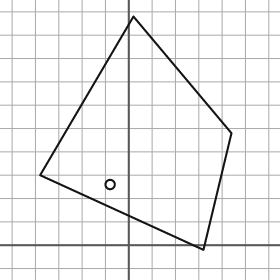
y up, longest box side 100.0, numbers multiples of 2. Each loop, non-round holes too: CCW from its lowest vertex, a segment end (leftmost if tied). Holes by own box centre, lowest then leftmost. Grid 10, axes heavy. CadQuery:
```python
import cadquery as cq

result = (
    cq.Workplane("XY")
    .moveTo(32.0, -2.0)
    .lineTo(44.0, 48.0)
    .lineTo(2.0, 98.0)
    .lineTo(-38.0, 30.0)
    .close()
    .moveTo(-8.0, 26.0)
    .circle(2.0)
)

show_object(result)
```